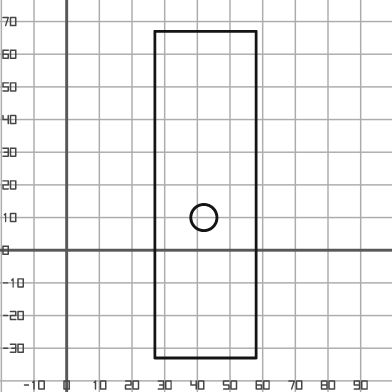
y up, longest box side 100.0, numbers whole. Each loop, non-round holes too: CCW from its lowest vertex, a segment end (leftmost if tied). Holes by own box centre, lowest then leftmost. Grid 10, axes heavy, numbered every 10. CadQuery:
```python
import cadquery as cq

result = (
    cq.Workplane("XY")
    .moveTo(27.0, -33.0)
    .lineTo(58.0, -33.0)
    .lineTo(58.0, 67.0)
    .lineTo(27.0, 67.0)
    .close()
    .moveTo(42.0, 10.0)
    .circle(4.0)
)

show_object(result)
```